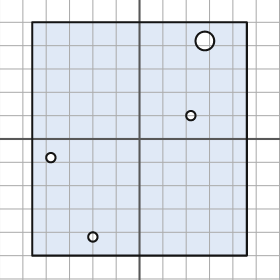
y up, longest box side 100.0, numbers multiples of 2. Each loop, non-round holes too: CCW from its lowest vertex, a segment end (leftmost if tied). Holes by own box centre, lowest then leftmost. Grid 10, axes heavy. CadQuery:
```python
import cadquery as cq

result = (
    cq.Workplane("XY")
    .moveTo(-46.0, -50.0)
    .lineTo(46.0, -50.0)
    .lineTo(46.0, 50.0)
    .lineTo(-46.0, 50.0)
    .close()
    .moveTo(-20.0, -42.0)
    .circle(2.0)
    .moveTo(-38.0, -8.0)
    .circle(2.0)
    .moveTo(22.0, 10.0)
    .circle(2.0)
    .moveTo(28.0, 42.0)
    .circle(4.0)
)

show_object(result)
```